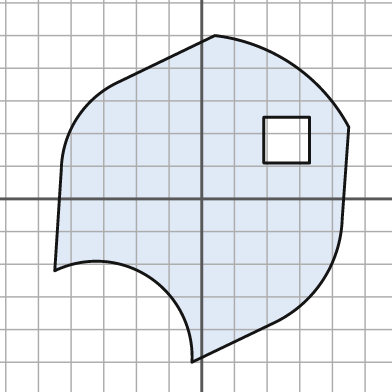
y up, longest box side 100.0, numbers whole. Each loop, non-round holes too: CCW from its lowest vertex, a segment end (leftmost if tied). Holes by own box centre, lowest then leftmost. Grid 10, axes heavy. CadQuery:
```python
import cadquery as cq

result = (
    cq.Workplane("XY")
    .moveTo(-3.0, -50.0)
    .lineTo(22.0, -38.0)
    .threePointArc((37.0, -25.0), (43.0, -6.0))
    .lineTo(45.0, 22.0)
    .threePointArc((28.0, 41.0), (4.0, 50.0))
    .lineTo(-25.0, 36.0)
    .threePointArc((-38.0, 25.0), (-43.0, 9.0))
    .lineTo(-45.0, -22.0)
    .threePointArc((-16.0, -24.0), (-3.0, -50.0))
    .close()
    .moveTo(19.0, 11.0)
    .lineTo(33.0, 11.0)
    .lineTo(33.0, 25.0)
    .lineTo(19.0, 25.0)
    .close()
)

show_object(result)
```